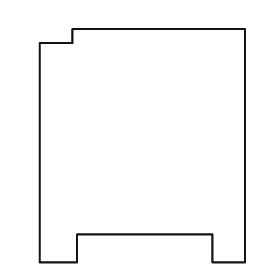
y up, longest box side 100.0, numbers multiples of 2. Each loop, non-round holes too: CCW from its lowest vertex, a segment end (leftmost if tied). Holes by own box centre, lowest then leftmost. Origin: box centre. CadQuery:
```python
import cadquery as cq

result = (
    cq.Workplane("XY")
    .moveTo(-44.0, -50.0)
    .lineTo(-28.0, -50.0)
    .lineTo(-28.0, -38.0)
    .lineTo(30.0, -38.0)
    .lineTo(30.0, -50.0)
    .lineTo(44.0, -50.0)
    .lineTo(44.0, 50.0)
    .lineTo(-30.0, 50.0)
    .lineTo(-30.0, 44.0)
    .lineTo(-44.0, 44.0)
    .close()
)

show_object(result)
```